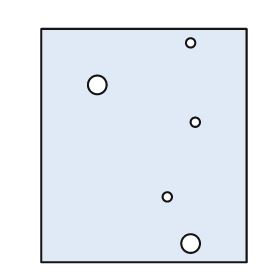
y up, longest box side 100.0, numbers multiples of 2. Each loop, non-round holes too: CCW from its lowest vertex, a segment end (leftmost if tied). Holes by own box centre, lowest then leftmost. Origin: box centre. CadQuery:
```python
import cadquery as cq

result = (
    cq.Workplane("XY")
    .moveTo(-44.0, -50.0)
    .lineTo(44.0, -50.0)
    .lineTo(44.0, 50.0)
    .lineTo(-44.0, 50.0)
    .close()
    .moveTo(20.0, -42.0)
    .circle(4.0)
    .moveTo(10.0, -22.0)
    .circle(2.0)
    .moveTo(22.0, 10.0)
    .circle(2.0)
    .moveTo(-20.0, 26.0)
    .circle(4.0)
    .moveTo(20.0, 44.0)
    .circle(2.0)
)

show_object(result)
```